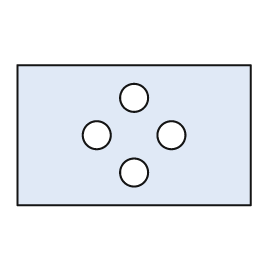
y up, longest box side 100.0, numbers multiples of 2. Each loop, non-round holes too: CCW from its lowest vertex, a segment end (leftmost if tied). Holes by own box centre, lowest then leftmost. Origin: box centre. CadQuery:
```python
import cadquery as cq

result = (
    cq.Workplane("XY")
    .moveTo(-50.0, -30.0)
    .lineTo(50.0, -30.0)
    .lineTo(50.0, 30.0)
    .lineTo(-50.0, 30.0)
    .close()
    .moveTo(0.0, -16.0)
    .circle(6.0)
    .moveTo(-16.0, 0.0)
    .circle(6.0)
    .moveTo(16.0, 0.0)
    .circle(6.0)
    .moveTo(0.0, 16.0)
    .circle(6.0)
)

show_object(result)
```